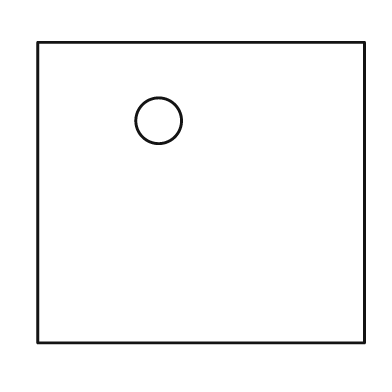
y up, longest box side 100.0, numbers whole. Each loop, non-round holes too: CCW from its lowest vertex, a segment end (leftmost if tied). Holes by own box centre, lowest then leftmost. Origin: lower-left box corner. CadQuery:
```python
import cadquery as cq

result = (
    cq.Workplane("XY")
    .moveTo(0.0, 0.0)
    .lineTo(100.0, 0.0)
    .lineTo(100.0, 92.0)
    .lineTo(0.0, 92.0)
    .close()
    .moveTo(37.0, 68.0)
    .circle(7.0)
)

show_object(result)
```